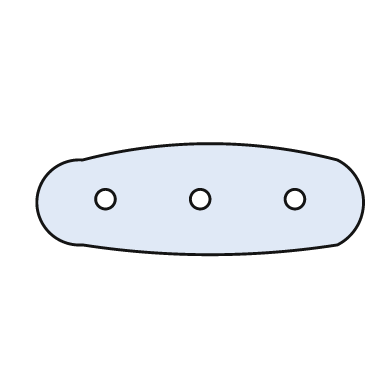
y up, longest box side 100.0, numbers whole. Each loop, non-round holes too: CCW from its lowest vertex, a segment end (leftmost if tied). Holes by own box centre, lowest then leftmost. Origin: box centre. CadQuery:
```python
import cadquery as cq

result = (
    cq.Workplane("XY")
    .moveTo(-36.0, -14.0)
    .threePointArc((3.0, -17.0), (42.0, -14.0))
    .threePointArc((50.0, -1.0), (42.0, 12.0))
    .threePointArc((3.0, 17.0), (-36.0, 12.0))
    .threePointArc((-50.0, -1.0), (-36.0, -14.0))
    .close()
    .moveTo(-29.0, 0.0)
    .circle(3.0)
    .moveTo(0.0, 0.0)
    .circle(3.0)
    .moveTo(29.0, 0.0)
    .circle(3.0)
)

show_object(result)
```